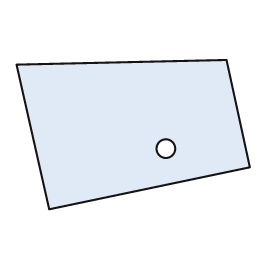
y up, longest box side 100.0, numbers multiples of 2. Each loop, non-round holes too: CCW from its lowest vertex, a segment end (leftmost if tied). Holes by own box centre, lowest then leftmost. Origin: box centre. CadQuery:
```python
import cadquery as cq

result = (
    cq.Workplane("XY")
    .moveTo(-36.0, -32.0)
    .lineTo(50.0, -14.0)
    .lineTo(40.0, 32.0)
    .lineTo(-50.0, 30.0)
    .close()
    .moveTo(14.0, -6.0)
    .circle(4.0)
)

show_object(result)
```